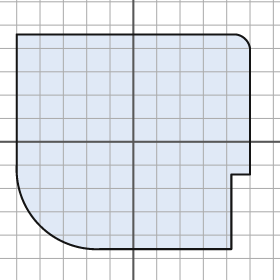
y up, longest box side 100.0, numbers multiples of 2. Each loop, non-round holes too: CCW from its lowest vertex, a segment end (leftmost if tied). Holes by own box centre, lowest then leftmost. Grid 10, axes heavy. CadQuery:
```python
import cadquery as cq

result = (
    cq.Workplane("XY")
    .moveTo(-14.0, -46.0)
    .lineTo(42.0, -46.0)
    .lineTo(42.0, -14.0)
    .lineTo(50.0, -14.0)
    .lineTo(50.0, 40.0)
    .threePointArc((48.0, 44.0), (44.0, 46.0))
    .lineTo(-50.0, 46.0)
    .lineTo(-50.0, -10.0)
    .threePointArc((-40.0, -36.0), (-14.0, -46.0))
    .close()
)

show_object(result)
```